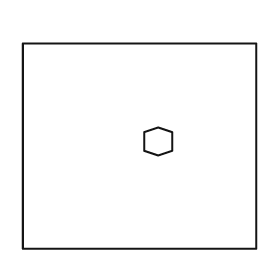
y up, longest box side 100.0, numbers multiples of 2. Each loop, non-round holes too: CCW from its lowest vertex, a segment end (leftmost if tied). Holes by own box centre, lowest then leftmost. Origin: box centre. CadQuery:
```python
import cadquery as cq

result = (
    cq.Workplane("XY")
    .moveTo(-50.0, -44.0)
    .lineTo(50.0, -44.0)
    .lineTo(50.0, 44.0)
    .lineTo(-50.0, 44.0)
    .close()
    .moveTo(8.0, -4.0)
    .lineTo(14.0, -2.0)
    .lineTo(14.0, 6.0)
    .lineTo(8.0, 8.0)
    .lineTo(2.0, 6.0)
    .lineTo(2.0, -2.0)
    .close()
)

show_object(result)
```